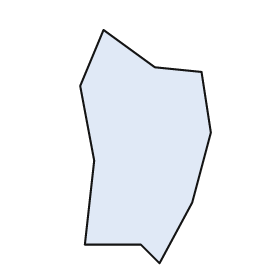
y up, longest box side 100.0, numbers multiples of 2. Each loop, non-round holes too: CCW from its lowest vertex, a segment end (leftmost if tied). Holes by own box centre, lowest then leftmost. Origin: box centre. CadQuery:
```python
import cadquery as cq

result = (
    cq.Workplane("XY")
    .moveTo(6.0, -50.0)
    .lineTo(20.0, -24.0)
    .lineTo(28.0, 6.0)
    .lineTo(24.0, 32.0)
    .lineTo(4.0, 34.0)
    .lineTo(-18.0, 50.0)
    .lineTo(-28.0, 26.0)
    .lineTo(-22.0, -6.0)
    .lineTo(-26.0, -42.0)
    .lineTo(-2.0, -42.0)
    .close()
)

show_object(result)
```